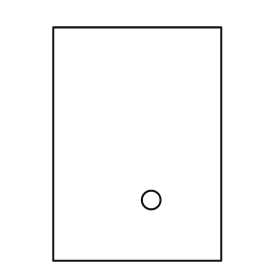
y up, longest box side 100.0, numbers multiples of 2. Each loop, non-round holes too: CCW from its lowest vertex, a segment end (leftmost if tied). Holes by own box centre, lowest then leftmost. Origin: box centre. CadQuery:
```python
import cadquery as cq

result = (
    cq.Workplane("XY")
    .moveTo(-36.0, -50.0)
    .lineTo(36.0, -50.0)
    .lineTo(36.0, 50.0)
    .lineTo(-36.0, 50.0)
    .close()
    .moveTo(6.0, -24.0)
    .circle(4.0)
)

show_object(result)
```